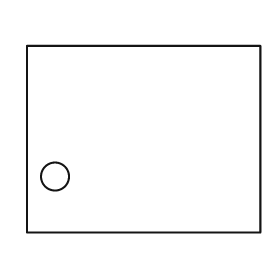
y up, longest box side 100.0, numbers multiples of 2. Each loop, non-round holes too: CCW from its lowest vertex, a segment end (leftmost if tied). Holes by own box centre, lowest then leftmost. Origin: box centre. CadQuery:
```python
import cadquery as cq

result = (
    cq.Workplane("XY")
    .moveTo(-50.0, -40.0)
    .lineTo(50.0, -40.0)
    .lineTo(50.0, 40.0)
    .lineTo(-50.0, 40.0)
    .close()
    .moveTo(-38.0, -16.0)
    .circle(6.0)
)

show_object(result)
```